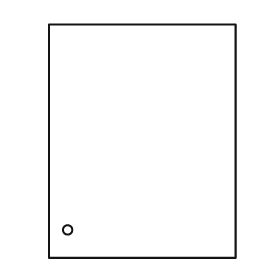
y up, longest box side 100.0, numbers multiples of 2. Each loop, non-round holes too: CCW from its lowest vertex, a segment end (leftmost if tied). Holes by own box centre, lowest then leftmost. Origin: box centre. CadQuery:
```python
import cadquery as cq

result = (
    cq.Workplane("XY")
    .moveTo(-40.0, -50.0)
    .lineTo(40.0, -50.0)
    .lineTo(40.0, 50.0)
    .lineTo(-40.0, 50.0)
    .close()
    .moveTo(-32.0, -38.0)
    .circle(2.0)
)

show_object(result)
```